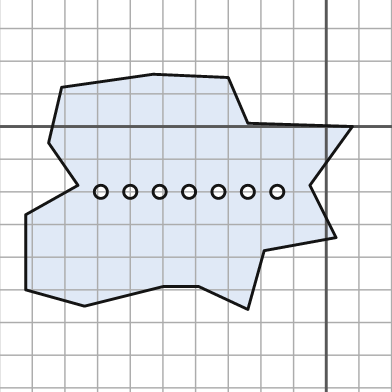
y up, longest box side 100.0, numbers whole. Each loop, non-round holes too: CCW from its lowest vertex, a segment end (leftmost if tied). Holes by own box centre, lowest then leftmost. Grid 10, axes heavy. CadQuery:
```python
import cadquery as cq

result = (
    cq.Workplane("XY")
    .moveTo(-24.0, -56.0)
    .lineTo(-19.0, -38.0)
    .lineTo(3.0, -34.0)
    .lineTo(-5.0, -18.0)
    .lineTo(8.0, 0.0)
    .lineTo(-24.0, 1.0)
    .lineTo(-30.0, 15.0)
    .lineTo(-53.0, 16.0)
    .lineTo(-81.0, 12.0)
    .lineTo(-85.0, -5.0)
    .lineTo(-76.0, -18.0)
    .lineTo(-92.0, -27.0)
    .lineTo(-92.0, -50.0)
    .lineTo(-74.0, -55.0)
    .lineTo(-50.0, -49.0)
    .lineTo(-39.0, -49.0)
    .close()
    .moveTo(-69.0, -20.0)
    .circle(2.0)
    .moveTo(-60.0, -20.0)
    .circle(2.0)
    .moveTo(-51.0, -20.0)
    .circle(2.0)
    .moveTo(-42.0, -20.0)
    .circle(2.0)
    .moveTo(-33.0, -20.0)
    .circle(2.0)
    .moveTo(-24.0, -20.0)
    .circle(2.0)
    .moveTo(-15.0, -20.0)
    .circle(2.0)
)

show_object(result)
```